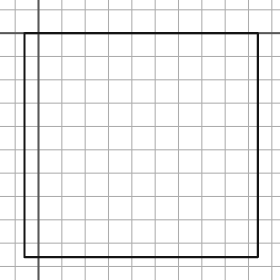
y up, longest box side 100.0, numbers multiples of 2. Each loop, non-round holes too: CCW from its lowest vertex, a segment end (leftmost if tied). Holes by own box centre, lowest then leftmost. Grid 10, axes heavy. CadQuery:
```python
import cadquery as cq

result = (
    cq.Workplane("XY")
    .moveTo(-6.0, -96.0)
    .lineTo(94.0, -96.0)
    .lineTo(94.0, 0.0)
    .lineTo(-6.0, 0.0)
    .close()
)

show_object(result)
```